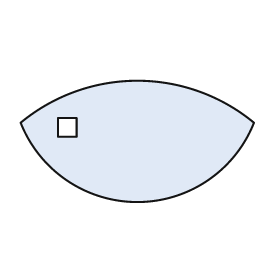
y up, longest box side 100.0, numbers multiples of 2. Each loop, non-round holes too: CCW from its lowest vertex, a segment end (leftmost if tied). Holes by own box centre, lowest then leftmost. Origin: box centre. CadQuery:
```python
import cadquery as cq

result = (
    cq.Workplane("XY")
    .moveTo(-50.0, 8.0)
    .threePointArc((0.0, -26.0), (50.0, 8.0))
    .threePointArc((0.0, 26.0), (-50.0, 8.0))
    .close()
    .moveTo(-34.0, 2.0)
    .lineTo(-26.0, 2.0)
    .lineTo(-26.0, 10.0)
    .lineTo(-34.0, 10.0)
    .close()
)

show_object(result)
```